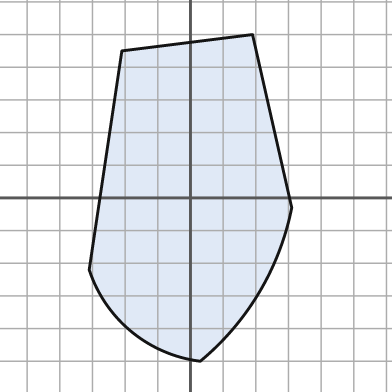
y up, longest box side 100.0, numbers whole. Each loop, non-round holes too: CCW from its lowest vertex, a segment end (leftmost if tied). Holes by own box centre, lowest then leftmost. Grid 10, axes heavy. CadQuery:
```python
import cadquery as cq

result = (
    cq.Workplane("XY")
    .moveTo(3.0, -50.0)
    .threePointArc((21.0, -29.0), (31.0, -3.0))
    .lineTo(19.0, 50.0)
    .lineTo(-21.0, 45.0)
    .lineTo(-31.0, -22.0)
    .threePointArc((-18.0, -41.0), (3.0, -50.0))
    .close()
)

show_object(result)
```